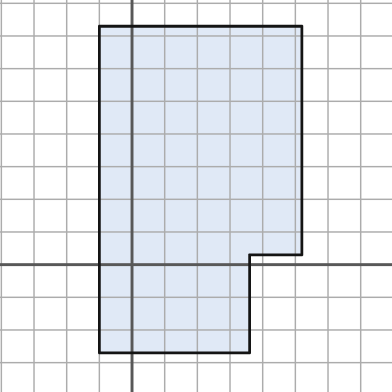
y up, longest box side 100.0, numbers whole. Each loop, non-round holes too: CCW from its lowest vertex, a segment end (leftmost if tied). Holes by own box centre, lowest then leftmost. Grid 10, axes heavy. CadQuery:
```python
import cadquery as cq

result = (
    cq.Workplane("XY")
    .moveTo(-10.0, -27.0)
    .lineTo(36.0, -27.0)
    .lineTo(36.0, 3.0)
    .lineTo(52.0, 3.0)
    .lineTo(52.0, 73.0)
    .lineTo(-10.0, 73.0)
    .close()
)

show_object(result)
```